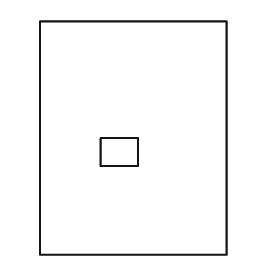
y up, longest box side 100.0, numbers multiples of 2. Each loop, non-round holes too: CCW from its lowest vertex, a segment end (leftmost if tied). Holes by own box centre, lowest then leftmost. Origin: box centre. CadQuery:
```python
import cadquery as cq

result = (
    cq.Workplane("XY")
    .moveTo(-40.0, -50.0)
    .lineTo(40.0, -50.0)
    .lineTo(40.0, 50.0)
    .lineTo(-40.0, 50.0)
    .close()
    .moveTo(-14.0, -12.0)
    .lineTo(2.0, -12.0)
    .lineTo(2.0, 0.0)
    .lineTo(-14.0, 0.0)
    .close()
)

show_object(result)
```